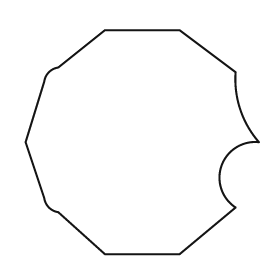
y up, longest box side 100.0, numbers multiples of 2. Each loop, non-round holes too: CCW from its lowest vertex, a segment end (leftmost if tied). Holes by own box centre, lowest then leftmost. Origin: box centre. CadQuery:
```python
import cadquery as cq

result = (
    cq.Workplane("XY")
    .moveTo(-16.0, -48.0)
    .lineTo(16.0, -48.0)
    .lineTo(40.0, -28.0)
    .threePointArc((34.0, -10.0), (50.0, 0.0))
    .threePointArc((42.0, 14.0), (40.0, 30.0))
    .lineTo(16.0, 48.0)
    .lineTo(-16.0, 48.0)
    .lineTo(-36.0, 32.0)
    .threePointArc((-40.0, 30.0), (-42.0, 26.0))
    .lineTo(-50.0, 0.0)
    .lineTo(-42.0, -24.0)
    .threePointArc((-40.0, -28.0), (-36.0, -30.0))
    .close()
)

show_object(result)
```